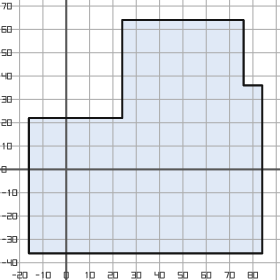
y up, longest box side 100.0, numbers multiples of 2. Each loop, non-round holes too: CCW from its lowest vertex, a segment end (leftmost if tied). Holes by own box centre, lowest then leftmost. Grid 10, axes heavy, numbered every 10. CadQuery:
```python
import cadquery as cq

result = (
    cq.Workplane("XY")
    .moveTo(-16.0, -36.0)
    .lineTo(84.0, -36.0)
    .lineTo(84.0, 36.0)
    .lineTo(76.0, 36.0)
    .lineTo(76.0, 64.0)
    .lineTo(24.0, 64.0)
    .lineTo(24.0, 22.0)
    .lineTo(-16.0, 22.0)
    .close()
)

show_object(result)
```